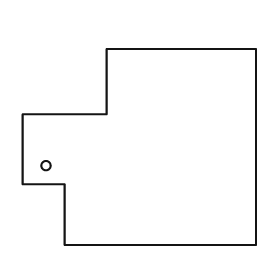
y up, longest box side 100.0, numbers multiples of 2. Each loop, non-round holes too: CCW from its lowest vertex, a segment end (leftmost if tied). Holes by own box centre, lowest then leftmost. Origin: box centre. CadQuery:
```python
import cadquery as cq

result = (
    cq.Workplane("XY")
    .moveTo(-32.0, -42.0)
    .lineTo(50.0, -42.0)
    .lineTo(50.0, 42.0)
    .lineTo(-14.0, 42.0)
    .lineTo(-14.0, 14.0)
    .lineTo(-50.0, 14.0)
    .lineTo(-50.0, -16.0)
    .lineTo(-32.0, -16.0)
    .close()
    .moveTo(-40.0, -8.0)
    .circle(2.0)
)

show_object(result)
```